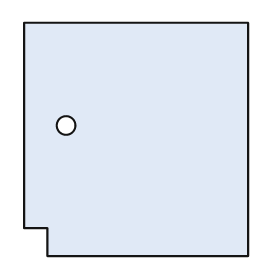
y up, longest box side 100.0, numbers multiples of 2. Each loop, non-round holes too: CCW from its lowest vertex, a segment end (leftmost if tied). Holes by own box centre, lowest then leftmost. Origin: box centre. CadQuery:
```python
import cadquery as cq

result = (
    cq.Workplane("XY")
    .moveTo(-38.0, -50.0)
    .lineTo(48.0, -50.0)
    .lineTo(48.0, 50.0)
    .lineTo(-48.0, 50.0)
    .lineTo(-48.0, -38.0)
    .lineTo(-38.0, -38.0)
    .close()
    .moveTo(-30.0, 6.0)
    .circle(4.0)
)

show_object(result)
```